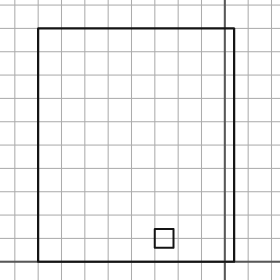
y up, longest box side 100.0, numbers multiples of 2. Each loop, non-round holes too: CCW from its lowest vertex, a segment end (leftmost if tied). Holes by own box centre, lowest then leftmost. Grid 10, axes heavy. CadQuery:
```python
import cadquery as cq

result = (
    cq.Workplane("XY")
    .moveTo(-80.0, 0.0)
    .lineTo(4.0, 0.0)
    .lineTo(4.0, 100.0)
    .lineTo(-80.0, 100.0)
    .close()
    .moveTo(-30.0, 6.0)
    .lineTo(-22.0, 6.0)
    .lineTo(-22.0, 14.0)
    .lineTo(-30.0, 14.0)
    .close()
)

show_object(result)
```